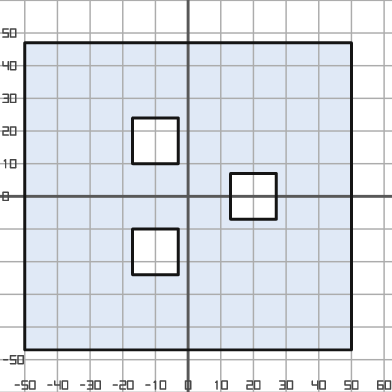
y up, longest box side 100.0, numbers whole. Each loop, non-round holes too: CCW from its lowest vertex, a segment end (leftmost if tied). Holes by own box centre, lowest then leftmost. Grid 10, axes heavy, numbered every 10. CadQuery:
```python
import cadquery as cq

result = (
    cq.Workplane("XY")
    .moveTo(-50.0, -47.0)
    .lineTo(50.0, -47.0)
    .lineTo(50.0, 47.0)
    .lineTo(-50.0, 47.0)
    .close()
    .moveTo(-17.0, -24.0)
    .lineTo(-3.0, -24.0)
    .lineTo(-3.0, -10.0)
    .lineTo(-17.0, -10.0)
    .close()
    .moveTo(13.0, -7.0)
    .lineTo(27.0, -7.0)
    .lineTo(27.0, 7.0)
    .lineTo(13.0, 7.0)
    .close()
    .moveTo(-17.0, 10.0)
    .lineTo(-3.0, 10.0)
    .lineTo(-3.0, 24.0)
    .lineTo(-17.0, 24.0)
    .close()
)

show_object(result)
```